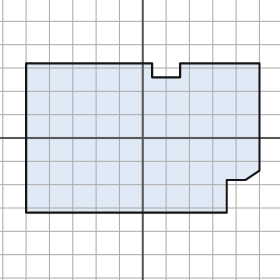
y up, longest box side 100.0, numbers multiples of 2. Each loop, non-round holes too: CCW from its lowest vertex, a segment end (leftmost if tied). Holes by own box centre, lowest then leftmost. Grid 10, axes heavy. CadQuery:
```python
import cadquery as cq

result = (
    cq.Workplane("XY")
    .moveTo(-50.0, -32.0)
    .lineTo(36.0, -32.0)
    .lineTo(36.0, -18.0)
    .lineTo(44.0, -18.0)
    .lineTo(50.0, -14.0)
    .lineTo(50.0, 32.0)
    .lineTo(16.0, 32.0)
    .lineTo(16.0, 26.0)
    .lineTo(4.0, 26.0)
    .lineTo(4.0, 32.0)
    .lineTo(-50.0, 32.0)
    .close()
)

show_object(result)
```